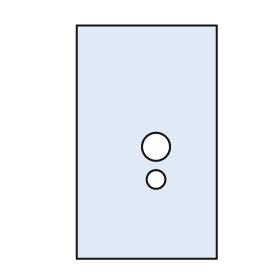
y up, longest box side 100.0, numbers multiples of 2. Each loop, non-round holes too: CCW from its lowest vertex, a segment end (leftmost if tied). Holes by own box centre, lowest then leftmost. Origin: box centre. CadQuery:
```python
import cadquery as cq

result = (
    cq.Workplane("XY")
    .moveTo(-30.0, -50.0)
    .lineTo(30.0, -50.0)
    .lineTo(30.0, 50.0)
    .lineTo(-30.0, 50.0)
    .close()
    .moveTo(4.0, -16.0)
    .circle(4.0)
    .moveTo(4.0, -2.0)
    .circle(6.0)
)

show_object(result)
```